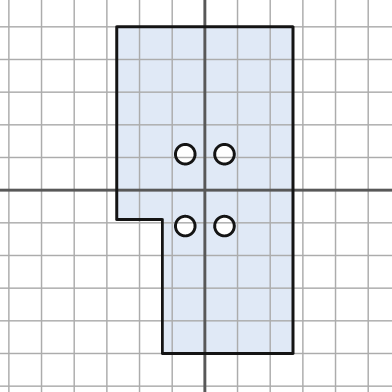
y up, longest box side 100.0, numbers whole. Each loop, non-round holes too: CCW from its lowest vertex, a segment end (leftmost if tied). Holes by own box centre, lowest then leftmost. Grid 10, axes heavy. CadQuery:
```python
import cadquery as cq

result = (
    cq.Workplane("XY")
    .moveTo(-13.0, -50.0)
    .lineTo(27.0, -50.0)
    .lineTo(27.0, 50.0)
    .lineTo(-27.0, 50.0)
    .lineTo(-27.0, -9.0)
    .lineTo(-13.0, -9.0)
    .close()
    .moveTo(-6.0, -11.0)
    .circle(3.0)
    .moveTo(6.0, -11.0)
    .circle(3.0)
    .moveTo(-6.0, 11.0)
    .circle(3.0)
    .moveTo(6.0, 11.0)
    .circle(3.0)
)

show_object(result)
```